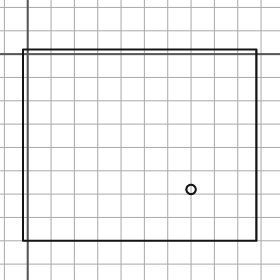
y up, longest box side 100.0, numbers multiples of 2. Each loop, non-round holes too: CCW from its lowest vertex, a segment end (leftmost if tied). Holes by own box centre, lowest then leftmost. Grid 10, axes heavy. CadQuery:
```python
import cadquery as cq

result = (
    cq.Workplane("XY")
    .moveTo(-2.0, -80.0)
    .lineTo(98.0, -80.0)
    .lineTo(98.0, 2.0)
    .lineTo(-2.0, 2.0)
    .close()
    .moveTo(70.0, -58.0)
    .circle(2.0)
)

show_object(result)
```